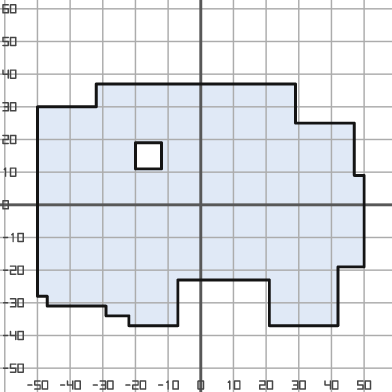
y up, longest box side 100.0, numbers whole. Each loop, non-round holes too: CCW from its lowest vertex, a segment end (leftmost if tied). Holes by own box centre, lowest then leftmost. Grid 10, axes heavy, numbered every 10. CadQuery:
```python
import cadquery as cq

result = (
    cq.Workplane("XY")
    .moveTo(-22.0, -37.0)
    .lineTo(-7.0, -37.0)
    .lineTo(-7.0, -23.0)
    .lineTo(21.0, -23.0)
    .lineTo(21.0, -37.0)
    .lineTo(42.0, -37.0)
    .lineTo(42.0, -19.0)
    .lineTo(50.0, -19.0)
    .lineTo(50.0, 9.0)
    .lineTo(47.0, 9.0)
    .lineTo(47.0, 25.0)
    .lineTo(29.0, 25.0)
    .lineTo(29.0, 37.0)
    .lineTo(-32.0, 37.0)
    .lineTo(-32.0, 30.0)
    .lineTo(-50.0, 30.0)
    .lineTo(-50.0, -28.0)
    .lineTo(-47.0, -28.0)
    .lineTo(-47.0, -31.0)
    .lineTo(-29.0, -31.0)
    .lineTo(-29.0, -34.0)
    .lineTo(-22.0, -34.0)
    .close()
    .moveTo(-20.0, 11.0)
    .lineTo(-12.0, 11.0)
    .lineTo(-12.0, 19.0)
    .lineTo(-20.0, 19.0)
    .close()
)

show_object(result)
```